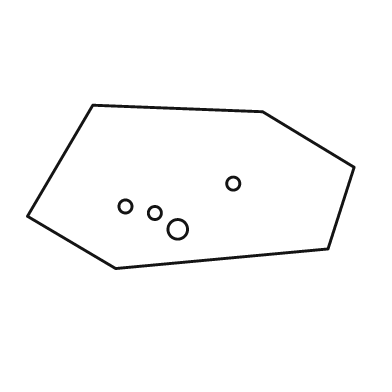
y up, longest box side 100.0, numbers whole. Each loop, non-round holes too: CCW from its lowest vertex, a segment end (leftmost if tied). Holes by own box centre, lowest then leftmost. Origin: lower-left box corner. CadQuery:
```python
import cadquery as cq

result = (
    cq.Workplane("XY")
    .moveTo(27.0, 0.0)
    .lineTo(92.0, 6.0)
    .lineTo(100.0, 31.0)
    .lineTo(72.0, 48.0)
    .lineTo(20.0, 50.0)
    .lineTo(0.0, 16.0)
    .close()
    .moveTo(46.0, 12.0)
    .circle(3.0)
    .moveTo(39.0, 17.0)
    .circle(2.0)
    .moveTo(30.0, 19.0)
    .circle(2.0)
    .moveTo(63.0, 26.0)
    .circle(2.0)
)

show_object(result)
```